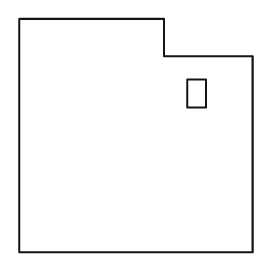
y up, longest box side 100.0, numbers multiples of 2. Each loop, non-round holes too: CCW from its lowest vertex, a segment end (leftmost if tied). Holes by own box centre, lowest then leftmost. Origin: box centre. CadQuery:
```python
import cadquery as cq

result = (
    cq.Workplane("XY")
    .moveTo(-50.0, -50.0)
    .lineTo(50.0, -50.0)
    .lineTo(50.0, 34.0)
    .lineTo(12.0, 34.0)
    .lineTo(12.0, 50.0)
    .lineTo(-50.0, 50.0)
    .close()
    .moveTo(22.0, 12.0)
    .lineTo(30.0, 12.0)
    .lineTo(30.0, 24.0)
    .lineTo(22.0, 24.0)
    .close()
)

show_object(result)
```